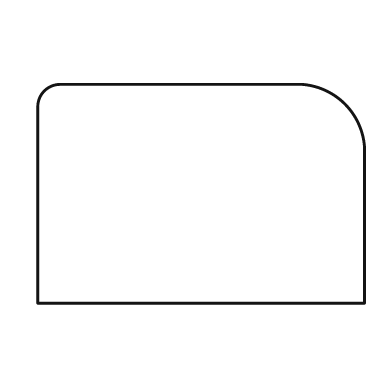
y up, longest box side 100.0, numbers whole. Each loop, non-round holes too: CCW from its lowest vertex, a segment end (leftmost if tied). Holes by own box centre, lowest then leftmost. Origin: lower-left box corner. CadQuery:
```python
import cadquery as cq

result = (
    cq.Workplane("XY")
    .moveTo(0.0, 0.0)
    .lineTo(100.0, 0.0)
    .lineTo(100.0, 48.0)
    .threePointArc((94.0, 61.0), (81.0, 67.0))
    .lineTo(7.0, 67.0)
    .threePointArc((2.0, 65.0), (0.0, 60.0))
    .close()
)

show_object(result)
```